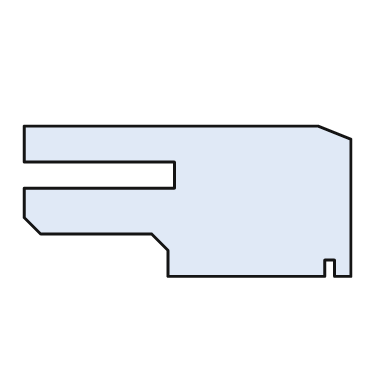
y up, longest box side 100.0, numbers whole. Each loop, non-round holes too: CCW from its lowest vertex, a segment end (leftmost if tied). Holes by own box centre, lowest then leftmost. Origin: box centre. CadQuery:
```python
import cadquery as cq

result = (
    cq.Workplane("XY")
    .moveTo(-6.0, -23.0)
    .lineTo(42.0, -23.0)
    .lineTo(42.0, -18.0)
    .lineTo(45.0, -18.0)
    .lineTo(45.0, -23.0)
    .lineTo(50.0, -23.0)
    .lineTo(50.0, 19.0)
    .lineTo(40.0, 23.0)
    .lineTo(-50.0, 23.0)
    .lineTo(-50.0, 12.0)
    .lineTo(-4.0, 12.0)
    .lineTo(-4.0, 4.0)
    .lineTo(-50.0, 4.0)
    .lineTo(-50.0, -5.0)
    .lineTo(-45.0, -10.0)
    .lineTo(-11.0, -10.0)
    .lineTo(-6.0, -15.0)
    .close()
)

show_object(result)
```